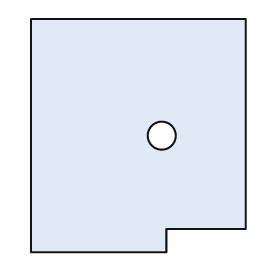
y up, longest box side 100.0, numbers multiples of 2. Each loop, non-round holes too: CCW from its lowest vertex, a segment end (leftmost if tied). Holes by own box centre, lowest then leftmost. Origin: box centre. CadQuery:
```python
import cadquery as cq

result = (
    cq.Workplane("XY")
    .moveTo(-46.0, -50.0)
    .lineTo(12.0, -50.0)
    .lineTo(12.0, -40.0)
    .lineTo(46.0, -40.0)
    .lineTo(46.0, 50.0)
    .lineTo(-46.0, 50.0)
    .close()
    .moveTo(10.0, 0.0)
    .circle(6.0)
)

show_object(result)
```